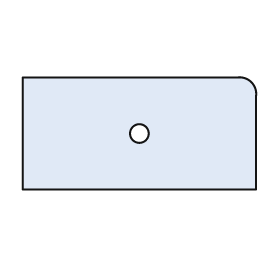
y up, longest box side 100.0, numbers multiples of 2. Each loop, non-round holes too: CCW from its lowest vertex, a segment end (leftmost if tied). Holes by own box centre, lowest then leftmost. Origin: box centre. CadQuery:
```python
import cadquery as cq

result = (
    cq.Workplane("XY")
    .moveTo(-50.0, -24.0)
    .lineTo(50.0, -24.0)
    .lineTo(50.0, 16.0)
    .threePointArc((48.0, 22.0), (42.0, 24.0))
    .lineTo(-50.0, 24.0)
    .close()
    .moveTo(0.0, 0.0)
    .circle(4.0)
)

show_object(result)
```